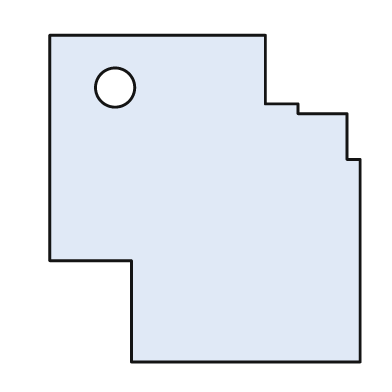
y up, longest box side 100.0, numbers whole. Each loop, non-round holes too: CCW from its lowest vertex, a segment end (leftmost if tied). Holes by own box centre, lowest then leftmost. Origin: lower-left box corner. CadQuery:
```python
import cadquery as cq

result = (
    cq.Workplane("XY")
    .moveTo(25.0, 0.0)
    .lineTo(95.0, 0.0)
    .lineTo(95.0, 62.0)
    .lineTo(91.0, 62.0)
    .lineTo(91.0, 76.0)
    .lineTo(76.0, 76.0)
    .lineTo(76.0, 79.0)
    .lineTo(66.0, 79.0)
    .lineTo(66.0, 100.0)
    .lineTo(0.0, 100.0)
    .lineTo(0.0, 31.0)
    .lineTo(25.0, 31.0)
    .close()
    .moveTo(20.0, 84.0)
    .circle(6.0)
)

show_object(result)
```